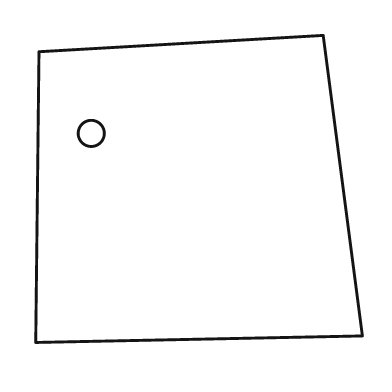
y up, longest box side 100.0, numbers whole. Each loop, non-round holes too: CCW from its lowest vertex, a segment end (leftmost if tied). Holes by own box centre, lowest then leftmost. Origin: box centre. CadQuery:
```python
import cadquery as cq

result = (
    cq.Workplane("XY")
    .moveTo(-50.0, -47.0)
    .lineTo(50.0, -45.0)
    .lineTo(38.0, 47.0)
    .lineTo(-49.0, 42.0)
    .close()
    .moveTo(-33.0, 17.0)
    .circle(4.0)
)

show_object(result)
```